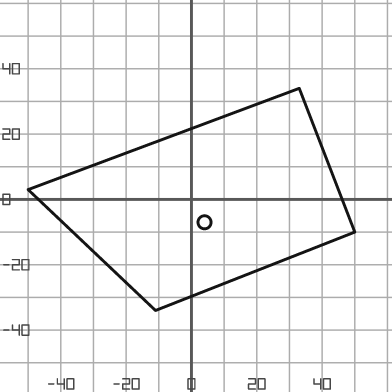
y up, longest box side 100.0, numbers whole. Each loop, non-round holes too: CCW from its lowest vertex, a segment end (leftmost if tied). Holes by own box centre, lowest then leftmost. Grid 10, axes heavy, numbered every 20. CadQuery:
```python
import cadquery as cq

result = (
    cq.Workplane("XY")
    .moveTo(-11.0, -34.0)
    .lineTo(50.0, -10.0)
    .lineTo(33.0, 34.0)
    .lineTo(-50.0, 3.0)
    .close()
    .moveTo(4.0, -7.0)
    .circle(2.0)
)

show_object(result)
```